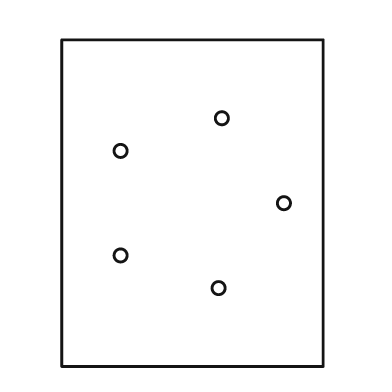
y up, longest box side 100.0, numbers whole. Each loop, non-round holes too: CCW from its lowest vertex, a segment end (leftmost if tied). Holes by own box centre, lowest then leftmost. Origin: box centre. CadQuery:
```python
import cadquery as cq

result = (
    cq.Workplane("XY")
    .moveTo(-40.0, -50.0)
    .lineTo(40.0, -50.0)
    .lineTo(40.0, 50.0)
    .lineTo(-40.0, 50.0)
    .close()
    .moveTo(8.0, -26.0)
    .circle(2.0)
    .moveTo(-22.0, -16.0)
    .circle(2.0)
    .moveTo(28.0, 0.0)
    .circle(2.0)
    .moveTo(-22.0, 16.0)
    .circle(2.0)
    .moveTo(9.0, 26.0)
    .circle(2.0)
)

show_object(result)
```